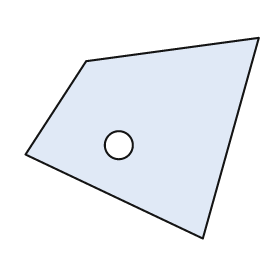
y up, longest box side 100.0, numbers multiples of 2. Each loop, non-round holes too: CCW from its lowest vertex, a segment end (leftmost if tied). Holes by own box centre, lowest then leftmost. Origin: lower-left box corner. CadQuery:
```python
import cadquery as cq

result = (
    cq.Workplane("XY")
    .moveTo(76.0, 0.0)
    .lineTo(100.0, 86.0)
    .lineTo(26.0, 76.0)
    .lineTo(0.0, 36.0)
    .close()
    .moveTo(40.0, 40.0)
    .circle(6.0)
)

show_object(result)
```